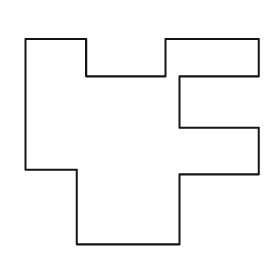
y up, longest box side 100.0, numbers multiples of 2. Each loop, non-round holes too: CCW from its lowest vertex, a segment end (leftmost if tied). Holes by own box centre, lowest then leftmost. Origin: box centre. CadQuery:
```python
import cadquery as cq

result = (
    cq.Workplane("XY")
    .moveTo(-28.0, -44.0)
    .lineTo(16.0, -44.0)
    .lineTo(16.0, -14.0)
    .lineTo(50.0, -14.0)
    .lineTo(50.0, 6.0)
    .lineTo(16.0, 6.0)
    .lineTo(16.0, 28.0)
    .lineTo(50.0, 28.0)
    .lineTo(50.0, 44.0)
    .lineTo(10.0, 44.0)
    .lineTo(10.0, 28.0)
    .lineTo(-24.0, 28.0)
    .lineTo(-24.0, 44.0)
    .lineTo(-50.0, 44.0)
    .lineTo(-50.0, -12.0)
    .lineTo(-28.0, -12.0)
    .close()
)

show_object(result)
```